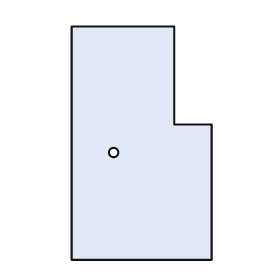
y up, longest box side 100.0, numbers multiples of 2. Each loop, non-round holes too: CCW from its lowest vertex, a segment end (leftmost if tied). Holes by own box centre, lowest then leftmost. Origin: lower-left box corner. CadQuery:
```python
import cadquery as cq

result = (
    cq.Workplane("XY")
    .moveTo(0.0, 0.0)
    .lineTo(60.0, 0.0)
    .lineTo(60.0, 58.0)
    .lineTo(44.0, 58.0)
    .lineTo(44.0, 100.0)
    .lineTo(0.0, 100.0)
    .close()
    .moveTo(18.0, 46.0)
    .circle(2.0)
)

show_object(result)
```